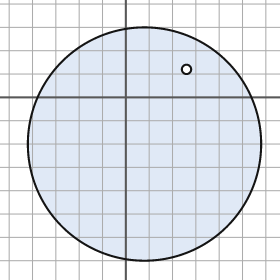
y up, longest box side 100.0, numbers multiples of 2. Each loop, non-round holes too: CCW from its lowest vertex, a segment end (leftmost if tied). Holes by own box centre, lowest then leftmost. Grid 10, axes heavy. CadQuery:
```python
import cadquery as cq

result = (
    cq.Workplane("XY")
    .moveTo(8.0, -20.0)
    .circle(50.0)
    .moveTo(26.0, 12.0)
    .circle(2.0)
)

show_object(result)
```